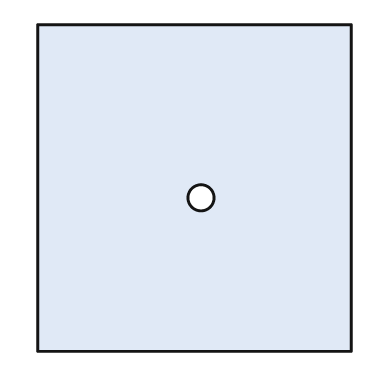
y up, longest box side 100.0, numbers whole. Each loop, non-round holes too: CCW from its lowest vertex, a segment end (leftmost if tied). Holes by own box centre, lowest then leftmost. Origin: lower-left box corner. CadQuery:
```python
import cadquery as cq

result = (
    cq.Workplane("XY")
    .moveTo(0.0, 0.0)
    .lineTo(96.0, 0.0)
    .lineTo(96.0, 100.0)
    .lineTo(0.0, 100.0)
    .close()
    .moveTo(50.0, 47.0)
    .circle(4.0)
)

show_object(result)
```